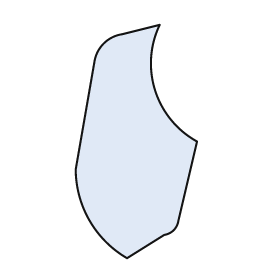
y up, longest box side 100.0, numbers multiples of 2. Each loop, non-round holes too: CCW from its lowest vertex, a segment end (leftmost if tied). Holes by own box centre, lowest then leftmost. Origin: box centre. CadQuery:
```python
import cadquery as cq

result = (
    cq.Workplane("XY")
    .moveTo(-4.0, -50.0)
    .lineTo(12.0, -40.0)
    .threePointArc((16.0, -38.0), (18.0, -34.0))
    .lineTo(26.0, 0.0)
    .threePointArc((8.0, 22.0), (10.0, 50.0))
    .lineTo(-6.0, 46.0)
    .threePointArc((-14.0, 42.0), (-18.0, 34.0))
    .lineTo(-26.0, -12.0)
    .threePointArc((-20.0, -34.0), (-4.0, -50.0))
    .close()
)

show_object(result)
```